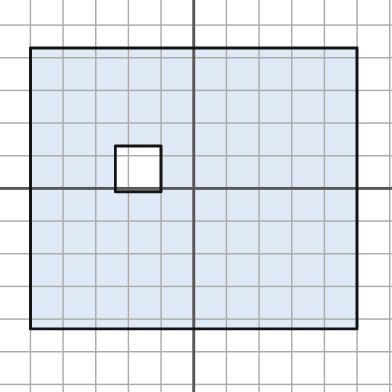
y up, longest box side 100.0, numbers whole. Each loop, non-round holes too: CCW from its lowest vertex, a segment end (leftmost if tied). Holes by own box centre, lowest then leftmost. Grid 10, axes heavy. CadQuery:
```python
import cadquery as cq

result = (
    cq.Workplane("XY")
    .moveTo(-50.0, -43.0)
    .lineTo(50.0, -43.0)
    .lineTo(50.0, 43.0)
    .lineTo(-50.0, 43.0)
    .close()
    .moveTo(-24.0, -1.0)
    .lineTo(-10.0, -1.0)
    .lineTo(-10.0, 13.0)
    .lineTo(-24.0, 13.0)
    .close()
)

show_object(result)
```